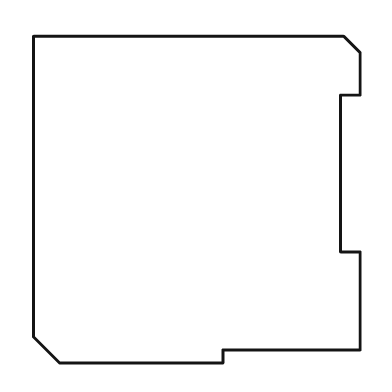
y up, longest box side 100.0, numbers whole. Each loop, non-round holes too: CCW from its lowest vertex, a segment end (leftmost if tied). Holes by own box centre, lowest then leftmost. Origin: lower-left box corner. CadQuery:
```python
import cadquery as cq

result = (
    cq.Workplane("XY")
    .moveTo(8.0, 0.0)
    .lineTo(58.0, 0.0)
    .lineTo(58.0, 4.0)
    .lineTo(100.0, 4.0)
    .lineTo(100.0, 34.0)
    .lineTo(94.0, 34.0)
    .lineTo(94.0, 82.0)
    .lineTo(100.0, 82.0)
    .lineTo(100.0, 95.0)
    .lineTo(95.0, 100.0)
    .lineTo(0.0, 100.0)
    .lineTo(0.0, 8.0)
    .close()
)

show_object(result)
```